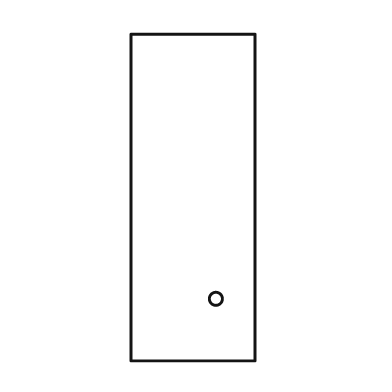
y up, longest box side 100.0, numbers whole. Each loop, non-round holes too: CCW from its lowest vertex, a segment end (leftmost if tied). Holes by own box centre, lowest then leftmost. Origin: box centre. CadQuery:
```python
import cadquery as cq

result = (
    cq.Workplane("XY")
    .moveTo(-19.0, -50.0)
    .lineTo(19.0, -50.0)
    .lineTo(19.0, 50.0)
    .lineTo(-19.0, 50.0)
    .close()
    .moveTo(7.0, -31.0)
    .circle(2.0)
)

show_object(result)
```